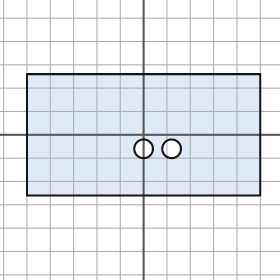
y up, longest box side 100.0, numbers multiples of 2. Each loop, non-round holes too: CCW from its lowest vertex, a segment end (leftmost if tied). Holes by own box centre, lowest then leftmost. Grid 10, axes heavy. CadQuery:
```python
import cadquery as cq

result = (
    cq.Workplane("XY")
    .moveTo(-50.0, -26.0)
    .lineTo(50.0, -26.0)
    .lineTo(50.0, 26.0)
    .lineTo(-50.0, 26.0)
    .close()
    .moveTo(0.0, -6.0)
    .circle(4.0)
    .moveTo(12.0, -6.0)
    .circle(4.0)
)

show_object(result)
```